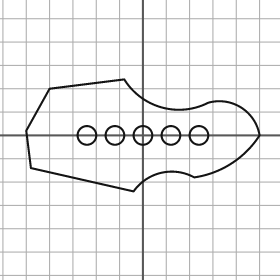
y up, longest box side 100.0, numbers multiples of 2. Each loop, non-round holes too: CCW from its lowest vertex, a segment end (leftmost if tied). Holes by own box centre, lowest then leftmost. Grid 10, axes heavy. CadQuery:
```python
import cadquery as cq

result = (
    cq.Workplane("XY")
    .moveTo(-4.0, -24.0)
    .threePointArc((8.0, -16.0), (22.0, -18.0))
    .threePointArc((38.0, -12.0), (50.0, 0.0))
    .threePointArc((42.0, 12.0), (28.0, 14.0))
    .threePointArc((8.0, 12.0), (-8.0, 24.0))
    .lineTo(-40.0, 20.0)
    .lineTo(-50.0, 2.0)
    .lineTo(-48.0, -14.0)
    .close()
    .moveTo(-24.0, 0.0)
    .circle(4.0)
    .moveTo(-12.0, 0.0)
    .circle(4.0)
    .moveTo(0.0, 0.0)
    .circle(4.0)
    .moveTo(12.0, 0.0)
    .circle(4.0)
    .moveTo(24.0, 0.0)
    .circle(4.0)
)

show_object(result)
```